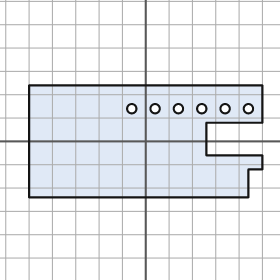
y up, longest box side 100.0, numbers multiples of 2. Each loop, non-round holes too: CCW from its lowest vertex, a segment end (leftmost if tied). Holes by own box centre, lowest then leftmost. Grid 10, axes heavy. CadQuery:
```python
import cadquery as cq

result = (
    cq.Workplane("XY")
    .moveTo(-50.0, -24.0)
    .lineTo(44.0, -24.0)
    .lineTo(44.0, -12.0)
    .lineTo(50.0, -12.0)
    .lineTo(50.0, -6.0)
    .lineTo(26.0, -6.0)
    .lineTo(26.0, 8.0)
    .lineTo(50.0, 8.0)
    .lineTo(50.0, 24.0)
    .lineTo(-50.0, 24.0)
    .close()
    .moveTo(-6.0, 14.0)
    .circle(2.0)
    .moveTo(4.0, 14.0)
    .circle(2.0)
    .moveTo(14.0, 14.0)
    .circle(2.0)
    .moveTo(24.0, 14.0)
    .circle(2.0)
    .moveTo(34.0, 14.0)
    .circle(2.0)
    .moveTo(44.0, 14.0)
    .circle(2.0)
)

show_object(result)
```